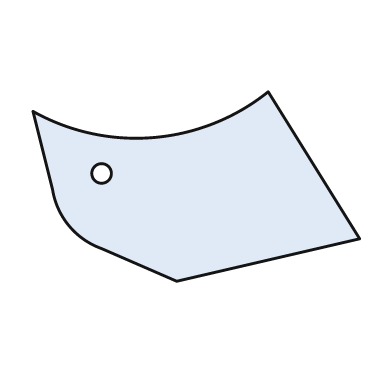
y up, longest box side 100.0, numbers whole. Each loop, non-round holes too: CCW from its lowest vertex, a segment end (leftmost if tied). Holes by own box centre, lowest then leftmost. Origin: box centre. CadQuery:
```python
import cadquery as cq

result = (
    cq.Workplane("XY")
    .moveTo(-6.0, -29.0)
    .lineTo(50.0, -16.0)
    .lineTo(22.0, 29.0)
    .threePointArc((-13.0, 15.0), (-50.0, 23.0))
    .lineTo(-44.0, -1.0)
    .threePointArc((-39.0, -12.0), (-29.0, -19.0))
    .close()
    .moveTo(-29.0, 4.0)
    .circle(3.0)
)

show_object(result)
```